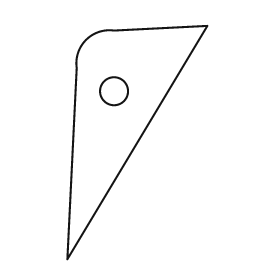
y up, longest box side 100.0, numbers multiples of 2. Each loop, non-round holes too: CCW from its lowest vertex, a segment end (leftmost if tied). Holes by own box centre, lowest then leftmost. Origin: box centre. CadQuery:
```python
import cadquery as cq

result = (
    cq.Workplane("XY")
    .moveTo(-30.0, -50.0)
    .lineTo(30.0, 50.0)
    .lineTo(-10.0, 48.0)
    .threePointArc((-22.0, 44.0), (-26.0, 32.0))
    .close()
    .moveTo(-10.0, 22.0)
    .circle(6.0)
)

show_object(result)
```